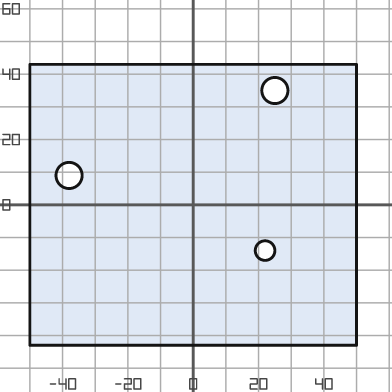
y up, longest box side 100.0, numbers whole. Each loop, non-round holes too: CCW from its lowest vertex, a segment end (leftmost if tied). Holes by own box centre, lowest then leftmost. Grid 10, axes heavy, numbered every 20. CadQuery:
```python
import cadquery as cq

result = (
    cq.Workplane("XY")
    .moveTo(-50.0, -43.0)
    .lineTo(50.0, -43.0)
    .lineTo(50.0, 43.0)
    .lineTo(-50.0, 43.0)
    .close()
    .moveTo(22.0, -14.0)
    .circle(3.0)
    .moveTo(-38.0, 9.0)
    .circle(4.0)
    .moveTo(25.0, 35.0)
    .circle(4.0)
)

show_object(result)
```